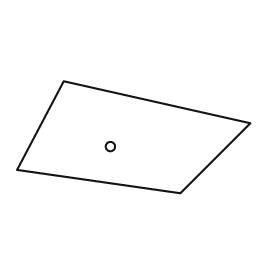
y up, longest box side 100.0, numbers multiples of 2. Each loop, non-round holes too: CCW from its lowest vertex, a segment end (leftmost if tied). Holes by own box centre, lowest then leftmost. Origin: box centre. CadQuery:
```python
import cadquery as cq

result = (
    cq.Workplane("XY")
    .moveTo(20.0, -24.0)
    .lineTo(50.0, 6.0)
    .lineTo(-30.0, 24.0)
    .lineTo(-50.0, -14.0)
    .close()
    .moveTo(-10.0, -4.0)
    .circle(2.0)
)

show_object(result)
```